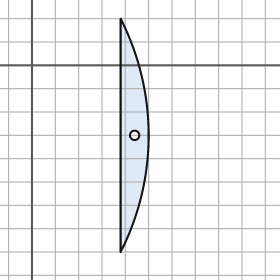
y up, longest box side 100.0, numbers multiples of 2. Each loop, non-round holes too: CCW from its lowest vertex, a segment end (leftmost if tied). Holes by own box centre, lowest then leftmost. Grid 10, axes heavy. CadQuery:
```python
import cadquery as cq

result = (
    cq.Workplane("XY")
    .moveTo(38.0, -80.0)
    .threePointArc((50.0, -30.0), (38.0, 20.0))
    .close()
    .moveTo(44.0, -30.0)
    .circle(2.0)
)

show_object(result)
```